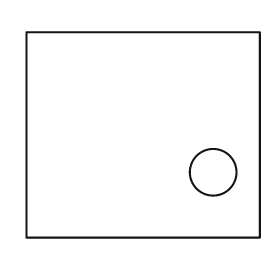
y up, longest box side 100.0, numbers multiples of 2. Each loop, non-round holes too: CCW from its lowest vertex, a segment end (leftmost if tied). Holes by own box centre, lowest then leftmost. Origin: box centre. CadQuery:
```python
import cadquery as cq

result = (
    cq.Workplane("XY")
    .moveTo(-50.0, -44.0)
    .lineTo(50.0, -44.0)
    .lineTo(50.0, 44.0)
    .lineTo(-50.0, 44.0)
    .close()
    .moveTo(30.0, -16.0)
    .circle(10.0)
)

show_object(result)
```